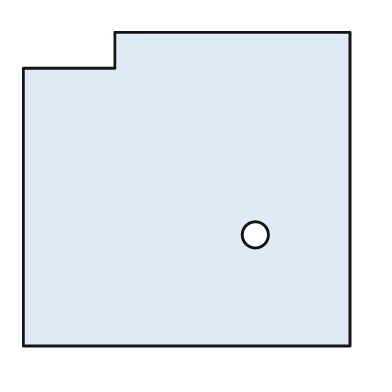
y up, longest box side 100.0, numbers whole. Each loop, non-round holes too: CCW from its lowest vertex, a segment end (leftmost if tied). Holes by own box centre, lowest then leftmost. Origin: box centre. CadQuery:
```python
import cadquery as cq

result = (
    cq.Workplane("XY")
    .moveTo(-50.0, -48.0)
    .lineTo(50.0, -48.0)
    .lineTo(50.0, 48.0)
    .lineTo(-22.0, 48.0)
    .lineTo(-22.0, 37.0)
    .lineTo(-50.0, 37.0)
    .close()
    .moveTo(21.0, -14.0)
    .circle(4.0)
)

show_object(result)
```